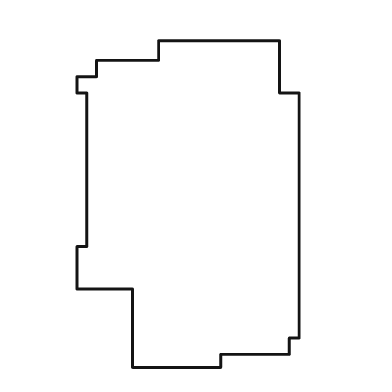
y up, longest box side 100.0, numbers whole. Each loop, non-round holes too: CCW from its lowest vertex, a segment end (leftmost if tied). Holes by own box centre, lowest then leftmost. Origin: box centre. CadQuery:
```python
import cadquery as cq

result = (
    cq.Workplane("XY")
    .moveTo(-17.0, -50.0)
    .lineTo(10.0, -50.0)
    .lineTo(10.0, -46.0)
    .lineTo(31.0, -46.0)
    .lineTo(31.0, -41.0)
    .lineTo(34.0, -41.0)
    .lineTo(34.0, 34.0)
    .lineTo(28.0, 34.0)
    .lineTo(28.0, 50.0)
    .lineTo(-9.0, 50.0)
    .lineTo(-9.0, 44.0)
    .lineTo(-28.0, 44.0)
    .lineTo(-28.0, 39.0)
    .lineTo(-34.0, 39.0)
    .lineTo(-34.0, 34.0)
    .lineTo(-31.0, 34.0)
    .lineTo(-31.0, -13.0)
    .lineTo(-34.0, -13.0)
    .lineTo(-34.0, -26.0)
    .lineTo(-17.0, -26.0)
    .close()
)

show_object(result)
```